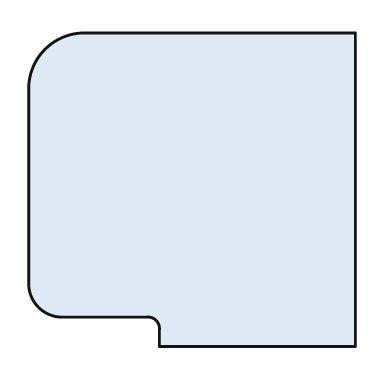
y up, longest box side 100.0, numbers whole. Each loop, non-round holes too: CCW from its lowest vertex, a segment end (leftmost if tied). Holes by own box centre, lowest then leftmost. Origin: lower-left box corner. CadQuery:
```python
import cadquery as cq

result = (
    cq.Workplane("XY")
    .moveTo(40.0, 0.0)
    .lineTo(100.0, 0.0)
    .lineTo(100.0, 96.0)
    .lineTo(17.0, 96.0)
    .threePointArc((5.0, 91.0), (0.0, 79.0))
    .lineTo(0.0, 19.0)
    .threePointArc((3.0, 12.0), (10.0, 9.0))
    .lineTo(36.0, 9.0)
    .threePointArc((39.0, 8.0), (40.0, 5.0))
    .close()
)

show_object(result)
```